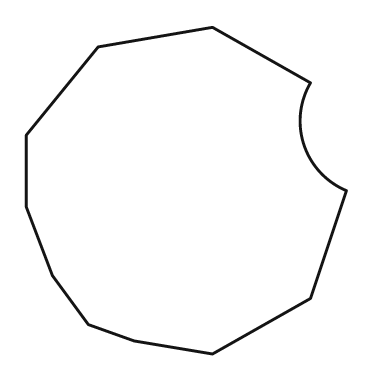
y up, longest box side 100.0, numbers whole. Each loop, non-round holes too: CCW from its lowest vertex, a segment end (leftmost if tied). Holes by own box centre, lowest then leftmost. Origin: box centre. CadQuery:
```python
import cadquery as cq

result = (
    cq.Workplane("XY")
    .moveTo(8.0, -50.0)
    .lineTo(38.0, -33.0)
    .lineTo(49.0, 0.0)
    .threePointArc((36.0, 14.0), (38.0, 33.0))
    .lineTo(8.0, 50.0)
    .lineTo(-27.0, 44.0)
    .lineTo(-49.0, 17.0)
    .lineTo(-49.0, -5.0)
    .lineTo(-41.0, -26.0)
    .lineTo(-30.0, -41.0)
    .lineTo(-16.0, -46.0)
    .close()
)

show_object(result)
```